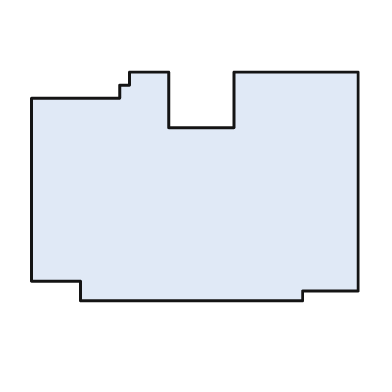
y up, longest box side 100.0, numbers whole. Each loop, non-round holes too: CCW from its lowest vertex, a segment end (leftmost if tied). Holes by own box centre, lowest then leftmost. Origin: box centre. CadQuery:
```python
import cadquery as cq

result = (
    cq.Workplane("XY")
    .moveTo(-35.0, -35.0)
    .lineTo(33.0, -35.0)
    .lineTo(33.0, -32.0)
    .lineTo(50.0, -32.0)
    .lineTo(50.0, 35.0)
    .lineTo(12.0, 35.0)
    .lineTo(12.0, 18.0)
    .lineTo(-8.0, 18.0)
    .lineTo(-8.0, 35.0)
    .lineTo(-20.0, 35.0)
    .lineTo(-20.0, 31.0)
    .lineTo(-23.0, 31.0)
    .lineTo(-23.0, 27.0)
    .lineTo(-50.0, 27.0)
    .lineTo(-50.0, -29.0)
    .lineTo(-35.0, -29.0)
    .close()
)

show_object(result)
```